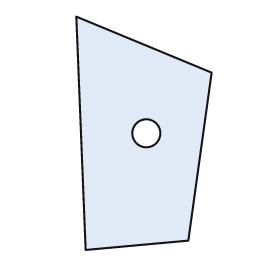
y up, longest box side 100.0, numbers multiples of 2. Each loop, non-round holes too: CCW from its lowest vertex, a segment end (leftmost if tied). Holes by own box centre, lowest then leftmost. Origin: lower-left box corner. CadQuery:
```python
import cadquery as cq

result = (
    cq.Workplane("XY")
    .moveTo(4.0, 0.0)
    .lineTo(48.0, 4.0)
    .lineTo(58.0, 76.0)
    .lineTo(0.0, 100.0)
    .close()
    .moveTo(30.0, 50.0)
    .circle(6.0)
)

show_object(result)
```